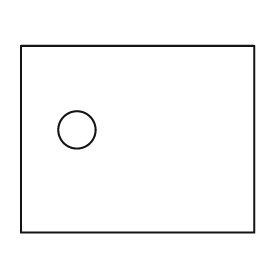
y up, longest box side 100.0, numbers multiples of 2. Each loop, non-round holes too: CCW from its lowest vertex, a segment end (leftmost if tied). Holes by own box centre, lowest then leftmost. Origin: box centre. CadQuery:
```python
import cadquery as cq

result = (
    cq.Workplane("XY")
    .moveTo(-50.0, -40.0)
    .lineTo(50.0, -40.0)
    .lineTo(50.0, 40.0)
    .lineTo(-50.0, 40.0)
    .close()
    .moveTo(-26.0, 4.0)
    .circle(8.0)
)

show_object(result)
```